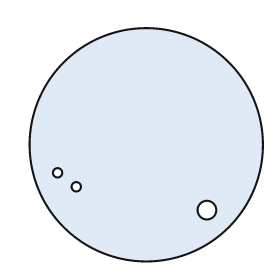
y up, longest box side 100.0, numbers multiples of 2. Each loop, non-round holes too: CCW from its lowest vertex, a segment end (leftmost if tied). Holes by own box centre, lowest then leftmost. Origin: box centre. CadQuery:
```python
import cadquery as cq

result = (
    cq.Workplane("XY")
    .moveTo(0.0, 0.0)
    .circle(50.0)
    .moveTo(26.0, -28.0)
    .circle(4.0)
    .moveTo(-30.0, -18.0)
    .circle(2.0)
    .moveTo(-38.0, -12.0)
    .circle(2.0)
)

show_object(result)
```